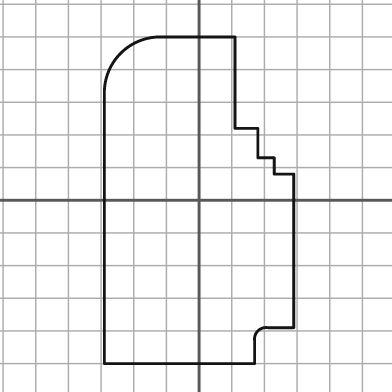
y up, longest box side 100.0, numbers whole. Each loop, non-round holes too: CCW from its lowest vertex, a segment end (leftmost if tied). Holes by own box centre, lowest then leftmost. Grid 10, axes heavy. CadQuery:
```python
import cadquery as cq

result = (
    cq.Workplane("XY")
    .moveTo(-29.0, -50.0)
    .lineTo(17.0, -50.0)
    .lineTo(17.0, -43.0)
    .threePointArc((18.0, -40.0), (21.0, -39.0))
    .lineTo(29.0, -39.0)
    .lineTo(29.0, 8.0)
    .lineTo(23.0, 8.0)
    .lineTo(23.0, 13.0)
    .lineTo(18.0, 13.0)
    .lineTo(18.0, 22.0)
    .lineTo(11.0, 22.0)
    .lineTo(11.0, 50.0)
    .lineTo(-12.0, 50.0)
    .threePointArc((-24.0, 45.0), (-29.0, 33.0))
    .close()
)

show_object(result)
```